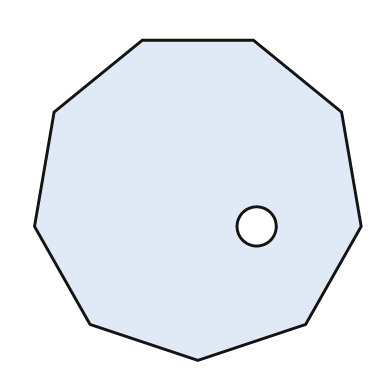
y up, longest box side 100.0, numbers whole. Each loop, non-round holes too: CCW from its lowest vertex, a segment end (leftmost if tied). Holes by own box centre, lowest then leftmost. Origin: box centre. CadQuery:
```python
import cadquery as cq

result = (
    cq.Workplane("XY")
    .moveTo(0.0, -49.0)
    .lineTo(33.0, -38.0)
    .lineTo(50.0, -8.0)
    .lineTo(44.0, 27.0)
    .lineTo(17.0, 49.0)
    .lineTo(-17.0, 49.0)
    .lineTo(-44.0, 27.0)
    .lineTo(-50.0, -8.0)
    .lineTo(-33.0, -38.0)
    .close()
    .moveTo(18.0, -8.0)
    .circle(6.0)
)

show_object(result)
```